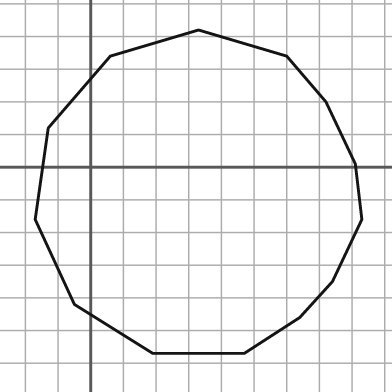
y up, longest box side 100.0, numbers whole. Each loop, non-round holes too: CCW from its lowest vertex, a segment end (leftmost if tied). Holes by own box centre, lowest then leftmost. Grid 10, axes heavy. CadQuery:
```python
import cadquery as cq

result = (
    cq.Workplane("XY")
    .moveTo(19.0, -57.0)
    .lineTo(47.0, -57.0)
    .lineTo(64.0, -46.0)
    .lineTo(74.0, -35.0)
    .lineTo(83.0, -16.0)
    .lineTo(81.0, 1.0)
    .lineTo(72.0, 20.0)
    .lineTo(60.0, 34.0)
    .lineTo(33.0, 42.0)
    .lineTo(6.0, 34.0)
    .lineTo(-13.0, 12.0)
    .lineTo(-17.0, -16.0)
    .lineTo(-5.0, -42.0)
    .close()
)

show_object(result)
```